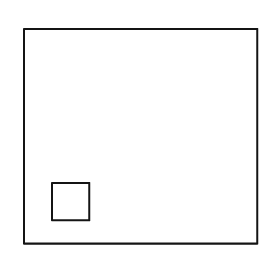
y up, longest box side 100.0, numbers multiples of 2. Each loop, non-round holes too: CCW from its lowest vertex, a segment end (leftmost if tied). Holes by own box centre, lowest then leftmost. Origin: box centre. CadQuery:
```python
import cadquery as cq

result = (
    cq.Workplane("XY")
    .moveTo(-50.0, -46.0)
    .lineTo(50.0, -46.0)
    .lineTo(50.0, 46.0)
    .lineTo(-50.0, 46.0)
    .close()
    .moveTo(-38.0, -36.0)
    .lineTo(-22.0, -36.0)
    .lineTo(-22.0, -20.0)
    .lineTo(-38.0, -20.0)
    .close()
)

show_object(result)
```